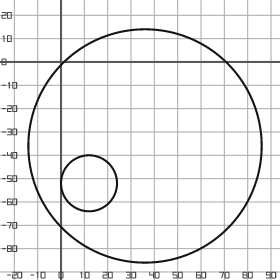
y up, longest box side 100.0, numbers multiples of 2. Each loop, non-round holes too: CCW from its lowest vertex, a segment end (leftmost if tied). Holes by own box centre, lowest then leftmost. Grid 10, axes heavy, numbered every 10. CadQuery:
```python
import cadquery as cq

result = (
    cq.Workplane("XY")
    .moveTo(36.0, -36.0)
    .circle(50.0)
    .moveTo(12.0, -52.0)
    .circle(12.0)
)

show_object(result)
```